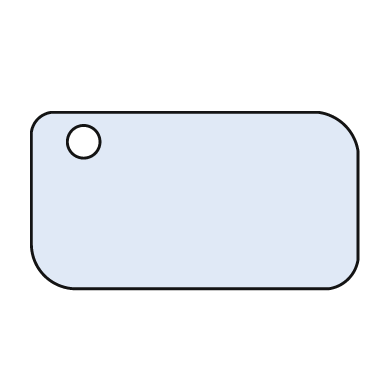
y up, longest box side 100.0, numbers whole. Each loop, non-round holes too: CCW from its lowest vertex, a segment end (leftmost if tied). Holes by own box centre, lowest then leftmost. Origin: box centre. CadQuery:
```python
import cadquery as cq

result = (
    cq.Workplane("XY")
    .moveTo(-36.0, -27.0)
    .lineTo(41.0, -27.0)
    .threePointArc((47.0, -24.0), (50.0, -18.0))
    .lineTo(50.0, 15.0)
    .threePointArc((46.0, 23.0), (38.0, 27.0))
    .lineTo(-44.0, 27.0)
    .threePointArc((-48.0, 25.0), (-50.0, 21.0))
    .lineTo(-50.0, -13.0)
    .threePointArc((-46.0, -23.0), (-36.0, -27.0))
    .close()
    .moveTo(-34.0, 18.0)
    .circle(5.0)
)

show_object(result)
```